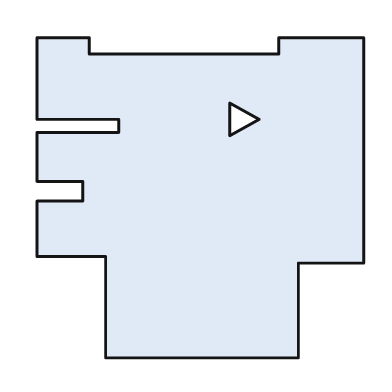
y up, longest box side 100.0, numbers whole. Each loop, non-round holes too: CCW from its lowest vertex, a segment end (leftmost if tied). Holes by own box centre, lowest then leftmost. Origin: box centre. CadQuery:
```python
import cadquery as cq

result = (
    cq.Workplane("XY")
    .moveTo(-29.0, -49.0)
    .lineTo(30.0, -49.0)
    .lineTo(30.0, -20.0)
    .lineTo(50.0, -20.0)
    .lineTo(50.0, 49.0)
    .lineTo(24.0, 49.0)
    .lineTo(24.0, 44.0)
    .lineTo(-34.0, 44.0)
    .lineTo(-34.0, 49.0)
    .lineTo(-50.0, 49.0)
    .lineTo(-50.0, 24.0)
    .lineTo(-25.0, 24.0)
    .lineTo(-25.0, 20.0)
    .lineTo(-50.0, 20.0)
    .lineTo(-50.0, 5.0)
    .lineTo(-36.0, 5.0)
    .lineTo(-36.0, -1.0)
    .lineTo(-50.0, -1.0)
    .lineTo(-50.0, -18.0)
    .lineTo(-29.0, -18.0)
    .close()
    .moveTo(9.0, 19.0)
    .lineTo(18.0, 24.0)
    .lineTo(9.0, 29.0)
    .close()
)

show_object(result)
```